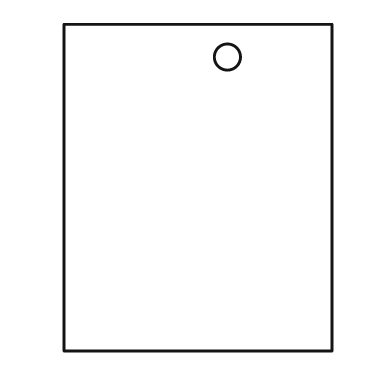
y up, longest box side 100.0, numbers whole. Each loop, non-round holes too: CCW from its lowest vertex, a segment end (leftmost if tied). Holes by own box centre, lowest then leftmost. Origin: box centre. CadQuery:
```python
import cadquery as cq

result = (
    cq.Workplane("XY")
    .moveTo(-41.0, -50.0)
    .lineTo(41.0, -50.0)
    .lineTo(41.0, 50.0)
    .lineTo(-41.0, 50.0)
    .close()
    .moveTo(9.0, 40.0)
    .circle(4.0)
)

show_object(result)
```